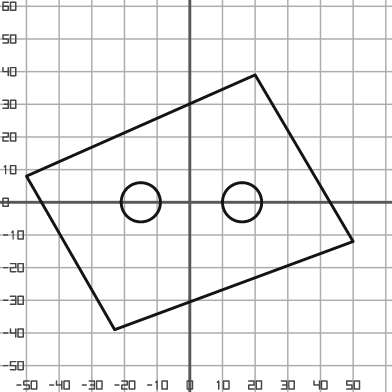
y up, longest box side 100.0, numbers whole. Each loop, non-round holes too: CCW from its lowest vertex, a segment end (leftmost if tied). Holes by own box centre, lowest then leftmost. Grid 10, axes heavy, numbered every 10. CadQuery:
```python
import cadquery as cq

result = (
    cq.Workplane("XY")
    .moveTo(-23.0, -39.0)
    .lineTo(50.0, -12.0)
    .lineTo(20.0, 39.0)
    .lineTo(-50.0, 8.0)
    .close()
    .moveTo(-15.0, 0.0)
    .circle(6.0)
    .moveTo(16.0, 0.0)
    .circle(6.0)
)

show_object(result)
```